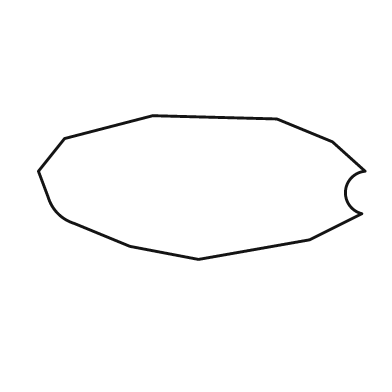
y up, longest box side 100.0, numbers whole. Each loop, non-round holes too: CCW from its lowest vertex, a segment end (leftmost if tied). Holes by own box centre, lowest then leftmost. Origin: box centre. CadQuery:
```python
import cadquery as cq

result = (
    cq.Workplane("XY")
    .moveTo(-1.0, -22.0)
    .lineTo(33.0, -16.0)
    .lineTo(49.0, -8.0)
    .threePointArc((44.0, -1.0), (50.0, 5.0))
    .lineTo(40.0, 14.0)
    .lineTo(23.0, 21.0)
    .lineTo(-15.0, 22.0)
    .lineTo(-42.0, 15.0)
    .lineTo(-50.0, 5.0)
    .lineTo(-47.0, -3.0)
    .threePointArc((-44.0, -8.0), (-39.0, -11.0))
    .lineTo(-22.0, -18.0)
    .close()
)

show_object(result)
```